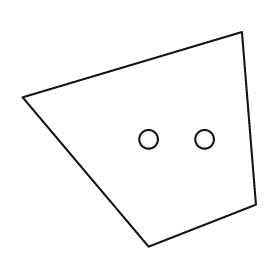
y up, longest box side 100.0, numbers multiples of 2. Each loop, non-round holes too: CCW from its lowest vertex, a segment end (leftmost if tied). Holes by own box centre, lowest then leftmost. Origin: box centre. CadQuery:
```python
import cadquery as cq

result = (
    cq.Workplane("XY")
    .moveTo(4.0, -46.0)
    .lineTo(50.0, -28.0)
    .lineTo(44.0, 46.0)
    .lineTo(-50.0, 18.0)
    .close()
    .moveTo(4.0, 0.0)
    .circle(4.0)
    .moveTo(28.0, 0.0)
    .circle(4.0)
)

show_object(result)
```